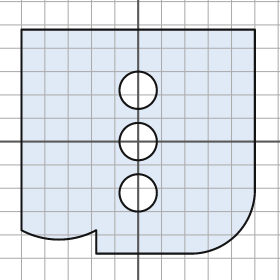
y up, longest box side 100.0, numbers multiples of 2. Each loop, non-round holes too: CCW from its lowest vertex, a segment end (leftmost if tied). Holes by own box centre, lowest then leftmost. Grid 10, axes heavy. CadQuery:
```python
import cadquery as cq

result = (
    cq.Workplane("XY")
    .moveTo(-18.0, -48.0)
    .lineTo(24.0, -48.0)
    .threePointArc((42.0, -40.0), (50.0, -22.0))
    .lineTo(50.0, 48.0)
    .lineTo(-50.0, 48.0)
    .lineTo(-50.0, -38.0)
    .threePointArc((-34.0, -42.0), (-18.0, -38.0))
    .close()
    .moveTo(0.0, -22.0)
    .circle(8.0)
    .moveTo(0.0, 0.0)
    .circle(8.0)
    .moveTo(0.0, 22.0)
    .circle(8.0)
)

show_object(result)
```